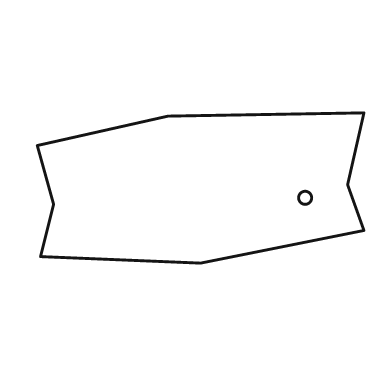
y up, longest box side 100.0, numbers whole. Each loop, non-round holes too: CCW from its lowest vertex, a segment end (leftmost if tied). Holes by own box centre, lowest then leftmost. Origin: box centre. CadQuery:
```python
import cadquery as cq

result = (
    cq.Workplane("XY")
    .moveTo(0.0, -23.0)
    .lineTo(50.0, -13.0)
    .lineTo(45.0, 1.0)
    .lineTo(50.0, 23.0)
    .lineTo(-10.0, 22.0)
    .lineTo(-50.0, 13.0)
    .lineTo(-45.0, -5.0)
    .lineTo(-49.0, -21.0)
    .close()
    .moveTo(32.0, -3.0)
    .circle(2.0)
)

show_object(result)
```